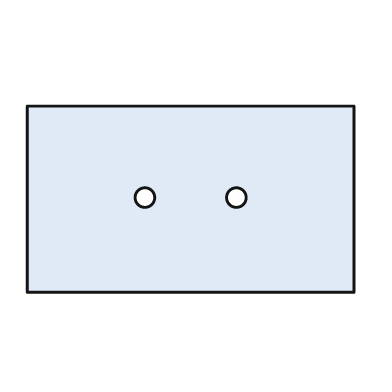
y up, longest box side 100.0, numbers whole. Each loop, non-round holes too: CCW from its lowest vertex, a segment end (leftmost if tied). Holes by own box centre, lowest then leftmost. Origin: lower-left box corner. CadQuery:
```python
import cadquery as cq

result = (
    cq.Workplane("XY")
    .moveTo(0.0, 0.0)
    .lineTo(100.0, 0.0)
    .lineTo(100.0, 57.0)
    .lineTo(0.0, 57.0)
    .close()
    .moveTo(36.0, 29.0)
    .circle(3.0)
    .moveTo(64.0, 29.0)
    .circle(3.0)
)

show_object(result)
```